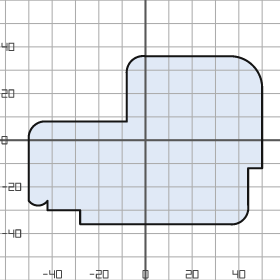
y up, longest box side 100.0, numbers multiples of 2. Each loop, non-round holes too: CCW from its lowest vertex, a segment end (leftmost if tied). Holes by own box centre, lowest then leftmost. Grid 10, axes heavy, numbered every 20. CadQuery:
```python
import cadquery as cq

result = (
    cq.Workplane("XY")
    .moveTo(-28.0, -36.0)
    .lineTo(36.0, -36.0)
    .threePointArc((42.0, -34.0), (44.0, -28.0))
    .lineTo(44.0, -12.0)
    .lineTo(50.0, -12.0)
    .lineTo(50.0, 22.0)
    .threePointArc((46.0, 32.0), (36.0, 36.0))
    .lineTo(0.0, 36.0)
    .threePointArc((-6.0, 34.0), (-8.0, 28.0))
    .lineTo(-8.0, 8.0)
    .lineTo(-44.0, 8.0)
    .threePointArc((-48.0, 6.0), (-50.0, 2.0))
    .lineTo(-50.0, -26.0)
    .threePointArc((-46.0, -28.0), (-42.0, -26.0))
    .lineTo(-42.0, -30.0)
    .lineTo(-28.0, -30.0)
    .close()
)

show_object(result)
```